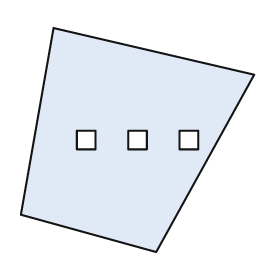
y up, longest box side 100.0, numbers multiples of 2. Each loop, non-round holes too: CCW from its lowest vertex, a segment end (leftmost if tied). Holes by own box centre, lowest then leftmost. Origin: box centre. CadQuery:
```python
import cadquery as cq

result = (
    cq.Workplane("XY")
    .moveTo(8.0, -48.0)
    .lineTo(50.0, 28.0)
    .lineTo(-36.0, 48.0)
    .lineTo(-50.0, -32.0)
    .close()
    .moveTo(-26.0, -4.0)
    .lineTo(-18.0, -4.0)
    .lineTo(-18.0, 4.0)
    .lineTo(-26.0, 4.0)
    .close()
    .moveTo(-4.0, -4.0)
    .lineTo(4.0, -4.0)
    .lineTo(4.0, 4.0)
    .lineTo(-4.0, 4.0)
    .close()
    .moveTo(18.0, -4.0)
    .lineTo(26.0, -4.0)
    .lineTo(26.0, 4.0)
    .lineTo(18.0, 4.0)
    .close()
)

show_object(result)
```